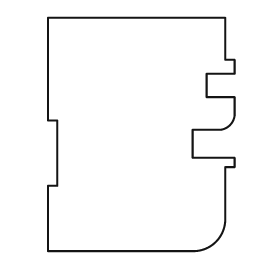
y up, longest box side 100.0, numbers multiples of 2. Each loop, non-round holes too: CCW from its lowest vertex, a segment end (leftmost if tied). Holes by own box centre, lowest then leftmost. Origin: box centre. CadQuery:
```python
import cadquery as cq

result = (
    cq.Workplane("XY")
    .moveTo(-40.0, -50.0)
    .lineTo(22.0, -50.0)
    .threePointArc((32.0, -46.0), (36.0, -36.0))
    .lineTo(36.0, -14.0)
    .lineTo(40.0, -14.0)
    .lineTo(40.0, -10.0)
    .lineTo(22.0, -10.0)
    .lineTo(22.0, 2.0)
    .lineTo(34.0, 2.0)
    .threePointArc((38.0, 4.0), (40.0, 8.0))
    .lineTo(40.0, 16.0)
    .lineTo(28.0, 16.0)
    .lineTo(28.0, 26.0)
    .lineTo(40.0, 26.0)
    .lineTo(40.0, 32.0)
    .lineTo(36.0, 32.0)
    .lineTo(36.0, 50.0)
    .lineTo(-40.0, 50.0)
    .lineTo(-40.0, 6.0)
    .lineTo(-36.0, 6.0)
    .lineTo(-36.0, -22.0)
    .lineTo(-40.0, -22.0)
    .close()
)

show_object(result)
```